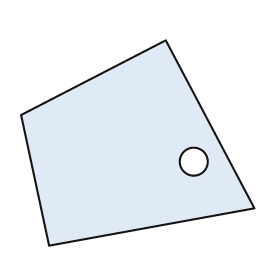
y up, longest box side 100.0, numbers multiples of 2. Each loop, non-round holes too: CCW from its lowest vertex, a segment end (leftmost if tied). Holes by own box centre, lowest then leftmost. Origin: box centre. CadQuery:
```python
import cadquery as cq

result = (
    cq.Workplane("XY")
    .moveTo(-38.0, -44.0)
    .lineTo(50.0, -28.0)
    .lineTo(12.0, 44.0)
    .lineTo(-50.0, 12.0)
    .close()
    .moveTo(24.0, -8.0)
    .circle(6.0)
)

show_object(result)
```